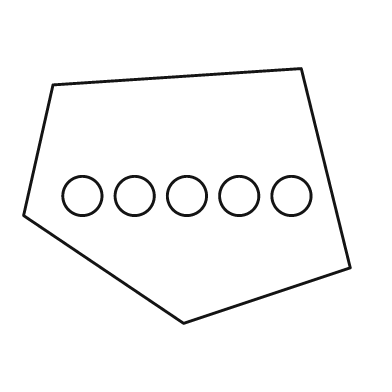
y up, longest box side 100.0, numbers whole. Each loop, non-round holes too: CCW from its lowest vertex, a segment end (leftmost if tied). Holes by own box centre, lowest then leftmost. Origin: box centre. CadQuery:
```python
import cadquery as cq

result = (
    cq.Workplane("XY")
    .moveTo(-1.0, -39.0)
    .lineTo(50.0, -22.0)
    .lineTo(35.0, 39.0)
    .lineTo(-41.0, 34.0)
    .lineTo(-50.0, -6.0)
    .close()
    .moveTo(-32.0, 0.0)
    .circle(6.0)
    .moveTo(-16.0, 0.0)
    .circle(6.0)
    .moveTo(0.0, 0.0)
    .circle(6.0)
    .moveTo(16.0, 0.0)
    .circle(6.0)
    .moveTo(32.0, 0.0)
    .circle(6.0)
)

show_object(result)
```